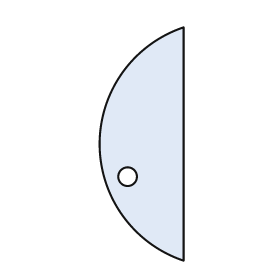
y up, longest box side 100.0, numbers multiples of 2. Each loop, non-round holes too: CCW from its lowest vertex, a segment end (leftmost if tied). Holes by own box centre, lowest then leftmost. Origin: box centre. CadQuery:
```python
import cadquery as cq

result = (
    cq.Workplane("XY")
    .moveTo(18.0, -50.0)
    .lineTo(18.0, 50.0)
    .threePointArc((-18.0, 0.0), (18.0, -50.0))
    .close()
    .moveTo(-6.0, -14.0)
    .circle(4.0)
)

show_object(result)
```